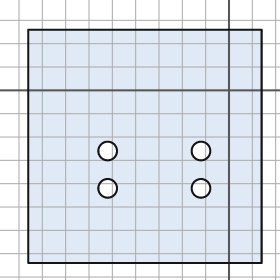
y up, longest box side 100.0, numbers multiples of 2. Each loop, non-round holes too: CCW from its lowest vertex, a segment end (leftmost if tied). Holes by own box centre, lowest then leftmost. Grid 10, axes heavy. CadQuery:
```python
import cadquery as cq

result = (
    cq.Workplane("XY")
    .moveTo(-86.0, -74.0)
    .lineTo(14.0, -74.0)
    .lineTo(14.0, 26.0)
    .lineTo(-86.0, 26.0)
    .close()
    .moveTo(-52.0, -42.0)
    .circle(4.0)
    .moveTo(-12.0, -42.0)
    .circle(4.0)
    .moveTo(-52.0, -26.0)
    .circle(4.0)
    .moveTo(-12.0, -26.0)
    .circle(4.0)
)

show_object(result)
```